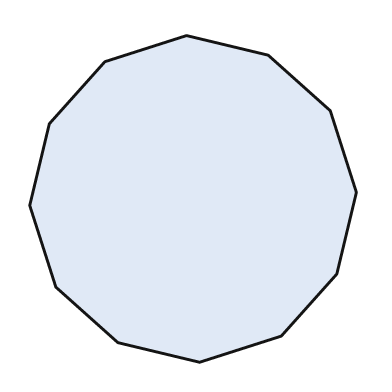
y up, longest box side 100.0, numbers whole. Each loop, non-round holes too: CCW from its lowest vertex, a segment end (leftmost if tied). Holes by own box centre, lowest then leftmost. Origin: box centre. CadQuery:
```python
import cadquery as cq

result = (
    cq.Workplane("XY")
    .moveTo(2.0, -50.0)
    .lineTo(27.0, -42.0)
    .lineTo(44.0, -23.0)
    .lineTo(50.0, 2.0)
    .lineTo(42.0, 27.0)
    .lineTo(23.0, 44.0)
    .lineTo(-2.0, 50.0)
    .lineTo(-27.0, 42.0)
    .lineTo(-44.0, 23.0)
    .lineTo(-50.0, -2.0)
    .lineTo(-42.0, -27.0)
    .lineTo(-23.0, -44.0)
    .close()
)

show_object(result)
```